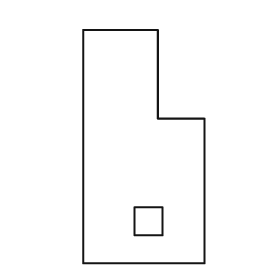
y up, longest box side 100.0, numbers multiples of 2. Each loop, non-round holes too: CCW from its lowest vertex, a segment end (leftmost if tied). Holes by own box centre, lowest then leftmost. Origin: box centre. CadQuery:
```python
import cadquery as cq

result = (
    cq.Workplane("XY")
    .moveTo(-26.0, -50.0)
    .lineTo(26.0, -50.0)
    .lineTo(26.0, 12.0)
    .lineTo(6.0, 12.0)
    .lineTo(6.0, 50.0)
    .lineTo(-26.0, 50.0)
    .close()
    .moveTo(-4.0, -38.0)
    .lineTo(8.0, -38.0)
    .lineTo(8.0, -26.0)
    .lineTo(-4.0, -26.0)
    .close()
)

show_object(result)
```